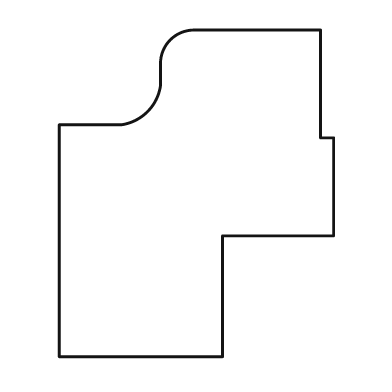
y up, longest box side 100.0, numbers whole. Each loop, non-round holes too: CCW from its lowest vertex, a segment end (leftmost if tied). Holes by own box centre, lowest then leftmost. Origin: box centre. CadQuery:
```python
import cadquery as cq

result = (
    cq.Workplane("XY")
    .moveTo(-42.0, -50.0)
    .lineTo(8.0, -50.0)
    .lineTo(8.0, -13.0)
    .lineTo(42.0, -13.0)
    .lineTo(42.0, 17.0)
    .lineTo(38.0, 17.0)
    .lineTo(38.0, 50.0)
    .lineTo(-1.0, 50.0)
    .threePointArc((-8.0, 47.0), (-11.0, 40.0))
    .lineTo(-11.0, 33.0)
    .threePointArc((-15.0, 25.0), (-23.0, 21.0))
    .lineTo(-42.0, 21.0)
    .close()
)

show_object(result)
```